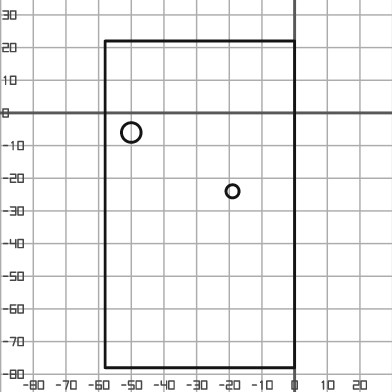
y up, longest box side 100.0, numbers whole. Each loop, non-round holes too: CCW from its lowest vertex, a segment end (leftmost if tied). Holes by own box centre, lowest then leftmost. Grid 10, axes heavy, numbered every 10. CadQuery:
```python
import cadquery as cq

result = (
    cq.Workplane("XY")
    .moveTo(-58.0, -78.0)
    .lineTo(0.0, -78.0)
    .lineTo(0.0, 22.0)
    .lineTo(-58.0, 22.0)
    .close()
    .moveTo(-19.0, -24.0)
    .circle(2.0)
    .moveTo(-50.0, -6.0)
    .circle(3.0)
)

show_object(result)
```